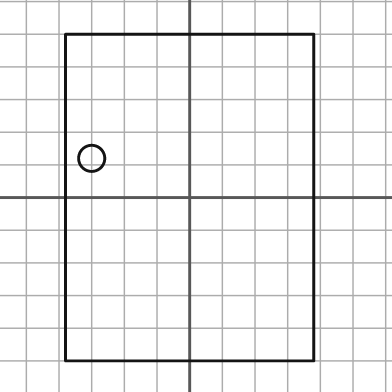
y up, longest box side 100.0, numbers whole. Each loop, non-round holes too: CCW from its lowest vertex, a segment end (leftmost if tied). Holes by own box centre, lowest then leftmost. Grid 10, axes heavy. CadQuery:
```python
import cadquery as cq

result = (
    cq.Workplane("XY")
    .moveTo(-38.0, -50.0)
    .lineTo(38.0, -50.0)
    .lineTo(38.0, 50.0)
    .lineTo(-38.0, 50.0)
    .close()
    .moveTo(-30.0, 12.0)
    .circle(4.0)
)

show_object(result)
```